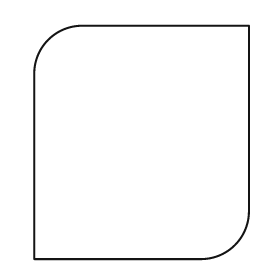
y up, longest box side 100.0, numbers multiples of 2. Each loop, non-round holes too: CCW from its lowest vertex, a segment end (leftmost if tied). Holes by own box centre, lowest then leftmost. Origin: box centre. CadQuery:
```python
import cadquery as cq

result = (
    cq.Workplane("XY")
    .moveTo(-46.0, -50.0)
    .lineTo(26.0, -50.0)
    .threePointArc((40.0, -44.0), (46.0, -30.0))
    .lineTo(46.0, 50.0)
    .lineTo(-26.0, 50.0)
    .threePointArc((-40.0, 44.0), (-46.0, 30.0))
    .close()
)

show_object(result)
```